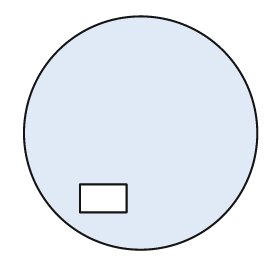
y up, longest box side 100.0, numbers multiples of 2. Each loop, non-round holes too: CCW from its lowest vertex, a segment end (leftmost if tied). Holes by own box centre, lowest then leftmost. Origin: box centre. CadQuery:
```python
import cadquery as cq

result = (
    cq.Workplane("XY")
    .moveTo(0.0, 0.0)
    .circle(50.0)
    .moveTo(-26.0, -34.0)
    .lineTo(-6.0, -34.0)
    .lineTo(-6.0, -22.0)
    .lineTo(-26.0, -22.0)
    .close()
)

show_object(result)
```